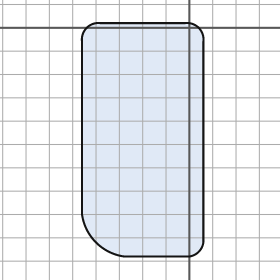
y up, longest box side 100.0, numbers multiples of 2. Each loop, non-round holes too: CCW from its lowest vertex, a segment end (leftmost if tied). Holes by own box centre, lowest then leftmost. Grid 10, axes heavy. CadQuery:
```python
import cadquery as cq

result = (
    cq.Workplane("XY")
    .moveTo(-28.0, -98.0)
    .lineTo(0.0, -98.0)
    .threePointArc((4.0, -96.0), (6.0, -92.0))
    .lineTo(6.0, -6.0)
    .threePointArc((4.0, 0.0), (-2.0, 2.0))
    .lineTo(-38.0, 2.0)
    .threePointArc((-44.0, 0.0), (-46.0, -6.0))
    .lineTo(-46.0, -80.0)
    .threePointArc((-40.0, -92.0), (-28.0, -98.0))
    .close()
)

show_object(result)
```